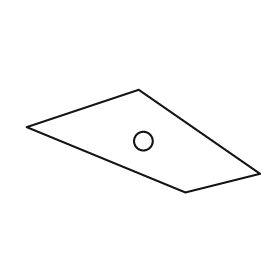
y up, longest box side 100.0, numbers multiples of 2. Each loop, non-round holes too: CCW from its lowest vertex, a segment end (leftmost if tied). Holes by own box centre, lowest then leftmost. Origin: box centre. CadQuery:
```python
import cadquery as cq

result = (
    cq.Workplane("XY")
    .moveTo(18.0, -22.0)
    .lineTo(50.0, -14.0)
    .lineTo(-2.0, 22.0)
    .lineTo(-50.0, 6.0)
    .close()
    .moveTo(0.0, 0.0)
    .circle(4.0)
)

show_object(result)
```